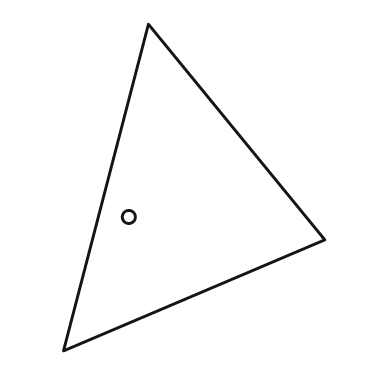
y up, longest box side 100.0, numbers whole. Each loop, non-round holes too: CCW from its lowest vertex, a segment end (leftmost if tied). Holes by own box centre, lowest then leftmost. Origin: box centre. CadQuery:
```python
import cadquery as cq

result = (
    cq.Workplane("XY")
    .moveTo(-40.0, -50.0)
    .lineTo(40.0, -16.0)
    .lineTo(-14.0, 50.0)
    .close()
    .moveTo(-20.0, -9.0)
    .circle(2.0)
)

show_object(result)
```